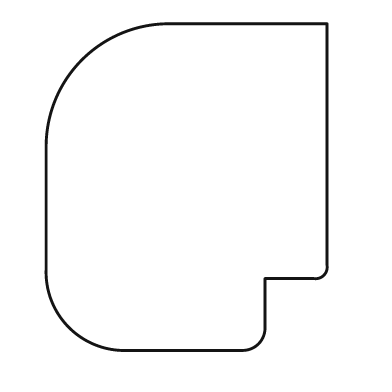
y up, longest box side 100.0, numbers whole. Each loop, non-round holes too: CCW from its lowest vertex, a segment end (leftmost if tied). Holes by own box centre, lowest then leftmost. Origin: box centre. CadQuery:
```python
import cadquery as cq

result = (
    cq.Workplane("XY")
    .moveTo(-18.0, -50.0)
    .lineTo(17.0, -50.0)
    .threePointArc((22.0, -48.0), (24.0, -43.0))
    .lineTo(24.0, -28.0)
    .lineTo(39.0, -28.0)
    .threePointArc((42.0, -27.0), (43.0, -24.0))
    .lineTo(43.0, 50.0)
    .lineTo(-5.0, 50.0)
    .threePointArc((-32.0, 39.0), (-43.0, 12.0))
    .lineTo(-43.0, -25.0)
    .threePointArc((-36.0, -43.0), (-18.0, -50.0))
    .close()
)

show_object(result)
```